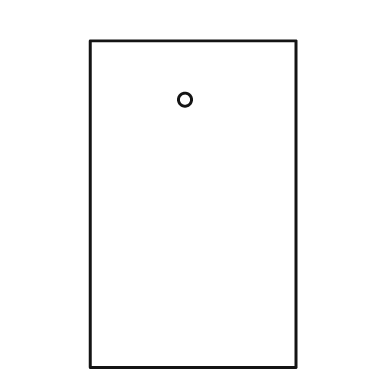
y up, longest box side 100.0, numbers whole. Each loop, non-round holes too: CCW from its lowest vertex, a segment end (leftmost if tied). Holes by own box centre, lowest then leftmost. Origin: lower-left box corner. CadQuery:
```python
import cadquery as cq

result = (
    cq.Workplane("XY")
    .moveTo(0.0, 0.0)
    .lineTo(63.0, 0.0)
    .lineTo(63.0, 100.0)
    .lineTo(0.0, 100.0)
    .close()
    .moveTo(29.0, 82.0)
    .circle(2.0)
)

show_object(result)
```